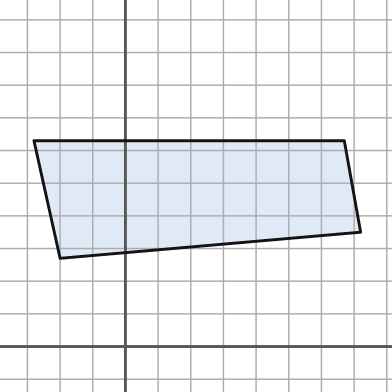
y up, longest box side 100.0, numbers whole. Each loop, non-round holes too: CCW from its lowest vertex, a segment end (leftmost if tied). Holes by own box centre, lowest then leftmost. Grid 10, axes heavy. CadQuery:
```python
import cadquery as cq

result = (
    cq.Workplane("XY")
    .moveTo(-20.0, 27.0)
    .lineTo(72.0, 35.0)
    .lineTo(67.0, 63.0)
    .lineTo(-28.0, 63.0)
    .close()
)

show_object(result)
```